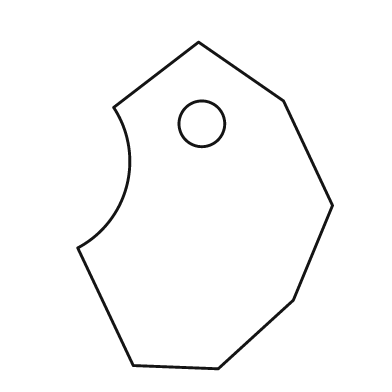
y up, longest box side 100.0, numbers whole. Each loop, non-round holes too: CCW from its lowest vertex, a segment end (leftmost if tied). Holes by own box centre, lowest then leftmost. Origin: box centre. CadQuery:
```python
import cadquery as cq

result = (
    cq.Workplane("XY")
    .moveTo(4.0, -50.0)
    .lineTo(27.0, -29.0)
    .lineTo(39.0, 0.0)
    .lineTo(24.0, 32.0)
    .lineTo(-2.0, 50.0)
    .lineTo(-28.0, 30.0)
    .threePointArc((-24.0, 6.0), (-39.0, -13.0))
    .lineTo(-22.0, -49.0)
    .close()
    .moveTo(-1.0, 25.0)
    .circle(7.0)
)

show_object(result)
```